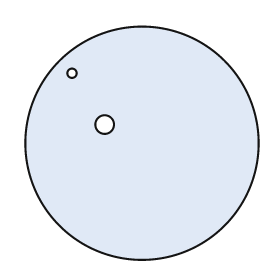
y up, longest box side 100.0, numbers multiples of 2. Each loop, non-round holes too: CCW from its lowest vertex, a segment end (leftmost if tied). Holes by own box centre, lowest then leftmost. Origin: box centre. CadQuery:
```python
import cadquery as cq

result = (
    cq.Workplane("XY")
    .moveTo(0.0, 0.0)
    .circle(50.0)
    .moveTo(-16.0, 8.0)
    .circle(4.0)
    .moveTo(-30.0, 30.0)
    .circle(2.0)
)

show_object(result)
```